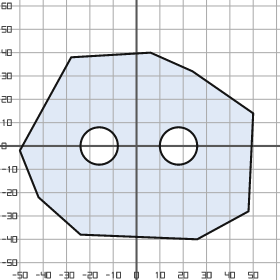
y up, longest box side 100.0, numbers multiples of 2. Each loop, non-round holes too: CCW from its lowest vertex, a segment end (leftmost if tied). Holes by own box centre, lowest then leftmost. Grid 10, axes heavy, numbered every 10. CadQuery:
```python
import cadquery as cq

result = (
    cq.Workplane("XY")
    .moveTo(26.0, -40.0)
    .lineTo(48.0, -28.0)
    .lineTo(50.0, 14.0)
    .lineTo(24.0, 32.0)
    .lineTo(6.0, 40.0)
    .lineTo(-28.0, 38.0)
    .lineTo(-50.0, -2.0)
    .lineTo(-42.0, -22.0)
    .lineTo(-24.0, -38.0)
    .close()
    .moveTo(-16.0, 0.0)
    .circle(8.0)
    .moveTo(18.0, 0.0)
    .circle(8.0)
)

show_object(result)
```